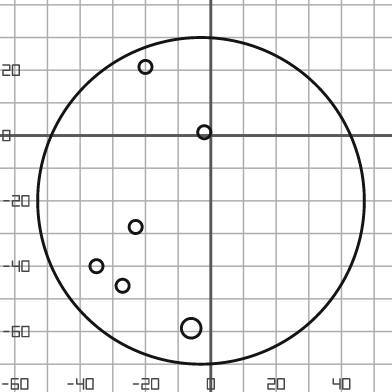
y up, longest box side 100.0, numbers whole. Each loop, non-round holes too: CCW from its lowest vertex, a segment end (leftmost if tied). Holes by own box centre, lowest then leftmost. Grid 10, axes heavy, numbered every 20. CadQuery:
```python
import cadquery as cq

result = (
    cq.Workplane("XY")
    .moveTo(-3.0, -20.0)
    .circle(50.0)
    .moveTo(-6.0, -59.0)
    .circle(3.0)
    .moveTo(-27.0, -46.0)
    .circle(2.0)
    .moveTo(-35.0, -40.0)
    .circle(2.0)
    .moveTo(-23.0, -28.0)
    .circle(2.0)
    .moveTo(-2.0, 1.0)
    .circle(2.0)
    .moveTo(-20.0, 21.0)
    .circle(2.0)
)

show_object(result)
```